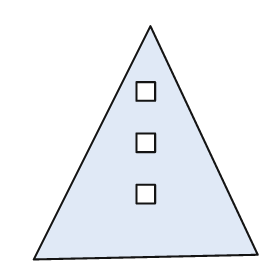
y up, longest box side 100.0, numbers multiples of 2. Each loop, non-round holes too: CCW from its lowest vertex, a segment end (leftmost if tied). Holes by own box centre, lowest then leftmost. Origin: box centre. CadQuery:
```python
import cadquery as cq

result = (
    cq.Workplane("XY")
    .moveTo(-48.0, -50.0)
    .lineTo(48.0, -48.0)
    .lineTo(2.0, 50.0)
    .close()
    .moveTo(-4.0, -26.0)
    .lineTo(4.0, -26.0)
    .lineTo(4.0, -18.0)
    .lineTo(-4.0, -18.0)
    .close()
    .moveTo(-4.0, -4.0)
    .lineTo(4.0, -4.0)
    .lineTo(4.0, 4.0)
    .lineTo(-4.0, 4.0)
    .close()
    .moveTo(-4.0, 18.0)
    .lineTo(4.0, 18.0)
    .lineTo(4.0, 26.0)
    .lineTo(-4.0, 26.0)
    .close()
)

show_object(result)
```